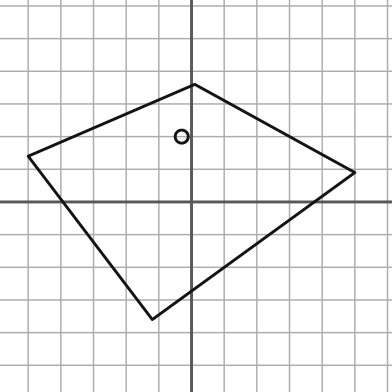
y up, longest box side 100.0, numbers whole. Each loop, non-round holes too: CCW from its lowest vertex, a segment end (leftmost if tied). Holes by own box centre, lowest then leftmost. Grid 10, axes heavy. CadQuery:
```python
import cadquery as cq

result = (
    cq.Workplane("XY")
    .moveTo(-12.0, -36.0)
    .lineTo(50.0, 9.0)
    .lineTo(1.0, 36.0)
    .lineTo(-50.0, 14.0)
    .close()
    .moveTo(-3.0, 20.0)
    .circle(2.0)
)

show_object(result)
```